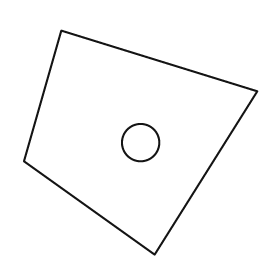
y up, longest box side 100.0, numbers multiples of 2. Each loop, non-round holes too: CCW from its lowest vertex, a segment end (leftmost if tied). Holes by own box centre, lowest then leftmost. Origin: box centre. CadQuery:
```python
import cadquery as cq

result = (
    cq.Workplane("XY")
    .moveTo(6.0, -48.0)
    .lineTo(50.0, 22.0)
    .lineTo(-34.0, 48.0)
    .lineTo(-50.0, -8.0)
    .close()
    .moveTo(0.0, 0.0)
    .circle(8.0)
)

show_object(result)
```